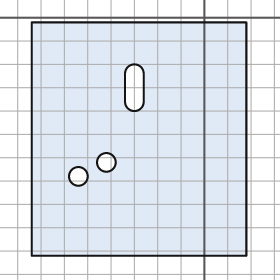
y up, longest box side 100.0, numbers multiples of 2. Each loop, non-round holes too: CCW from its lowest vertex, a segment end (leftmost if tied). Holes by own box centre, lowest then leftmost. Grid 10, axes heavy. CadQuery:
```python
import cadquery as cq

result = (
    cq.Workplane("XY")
    .moveTo(-74.0, -102.0)
    .lineTo(18.0, -102.0)
    .lineTo(18.0, -2.0)
    .lineTo(-74.0, -2.0)
    .close()
    .moveTo(-54.0, -68.0)
    .circle(4.0)
    .moveTo(-42.0, -62.0)
    .circle(4.0)
    .moveTo(-34.0, -36.0)
    .threePointArc((-30.0, -40.0), (-26.0, -36.0))
    .lineTo(-26.0, -24.0)
    .threePointArc((-30.0, -20.0), (-34.0, -24.0))
    .close()
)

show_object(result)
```